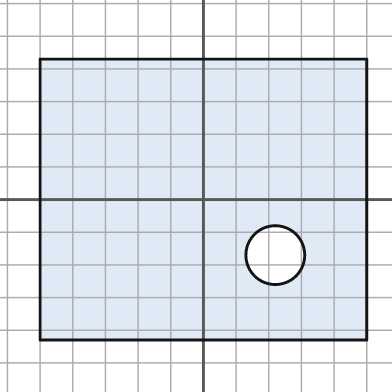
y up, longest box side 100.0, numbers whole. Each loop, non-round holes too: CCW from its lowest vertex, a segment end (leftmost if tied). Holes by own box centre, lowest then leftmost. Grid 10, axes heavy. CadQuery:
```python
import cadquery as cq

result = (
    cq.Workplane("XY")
    .moveTo(-50.0, -43.0)
    .lineTo(50.0, -43.0)
    .lineTo(50.0, 43.0)
    .lineTo(-50.0, 43.0)
    .close()
    .moveTo(22.0, -17.0)
    .circle(9.0)
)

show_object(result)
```